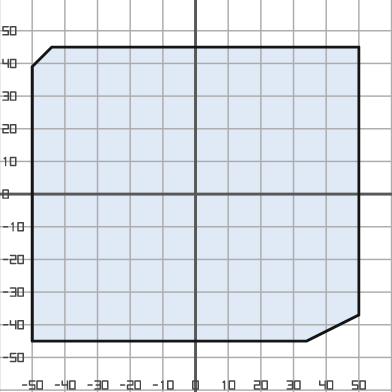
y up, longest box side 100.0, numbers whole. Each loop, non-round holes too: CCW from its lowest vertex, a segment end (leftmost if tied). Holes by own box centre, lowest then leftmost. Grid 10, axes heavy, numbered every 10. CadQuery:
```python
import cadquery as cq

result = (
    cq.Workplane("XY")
    .moveTo(-50.0, -45.0)
    .lineTo(34.0, -45.0)
    .lineTo(50.0, -37.0)
    .lineTo(50.0, 45.0)
    .lineTo(-44.0, 45.0)
    .lineTo(-50.0, 39.0)
    .close()
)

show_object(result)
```